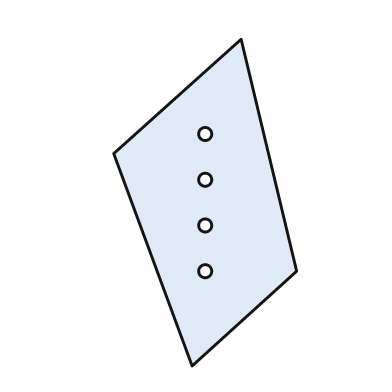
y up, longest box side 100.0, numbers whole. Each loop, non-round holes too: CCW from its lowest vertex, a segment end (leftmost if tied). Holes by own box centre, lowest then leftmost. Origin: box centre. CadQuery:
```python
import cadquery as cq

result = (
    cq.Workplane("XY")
    .moveTo(-4.0, -50.0)
    .lineTo(28.0, -21.0)
    .lineTo(11.0, 50.0)
    .lineTo(-28.0, 15.0)
    .close()
    .moveTo(0.0, -21.0)
    .circle(2.0)
    .moveTo(0.0, -7.0)
    .circle(2.0)
    .moveTo(0.0, 7.0)
    .circle(2.0)
    .moveTo(0.0, 21.0)
    .circle(2.0)
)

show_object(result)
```